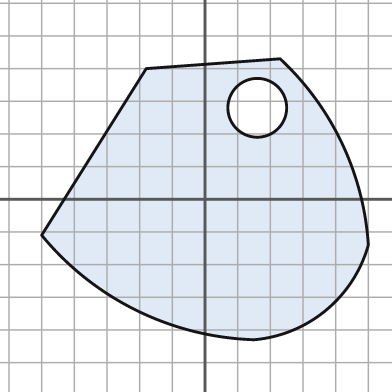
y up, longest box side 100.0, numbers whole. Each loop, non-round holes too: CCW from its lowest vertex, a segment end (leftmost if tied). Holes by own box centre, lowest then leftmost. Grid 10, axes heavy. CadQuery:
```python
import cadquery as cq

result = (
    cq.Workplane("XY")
    .moveTo(15.0, -43.0)
    .threePointArc((37.0, -34.0), (50.0, -14.0))
    .threePointArc((42.0, 17.0), (23.0, 43.0))
    .lineTo(-18.0, 40.0)
    .lineTo(-50.0, -11.0)
    .threePointArc((-21.0, -34.0), (15.0, -43.0))
    .close()
    .moveTo(16.0, 28.0)
    .circle(9.0)
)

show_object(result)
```